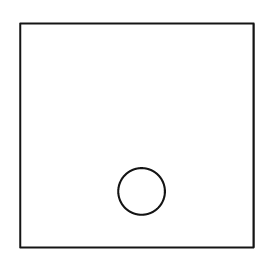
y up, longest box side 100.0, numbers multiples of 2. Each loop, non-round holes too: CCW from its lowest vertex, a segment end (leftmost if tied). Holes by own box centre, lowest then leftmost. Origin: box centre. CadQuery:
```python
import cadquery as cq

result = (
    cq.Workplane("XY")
    .moveTo(-50.0, -48.0)
    .lineTo(50.0, -48.0)
    .lineTo(50.0, 48.0)
    .lineTo(-50.0, 48.0)
    .close()
    .moveTo(2.0, -24.0)
    .circle(10.0)
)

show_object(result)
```